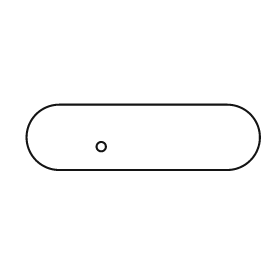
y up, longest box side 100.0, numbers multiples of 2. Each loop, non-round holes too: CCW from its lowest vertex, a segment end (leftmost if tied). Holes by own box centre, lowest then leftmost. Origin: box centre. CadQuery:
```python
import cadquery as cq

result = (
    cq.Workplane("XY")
    .moveTo(-36.0, -14.0)
    .lineTo(36.0, -14.0)
    .threePointArc((50.0, 0.0), (36.0, 14.0))
    .lineTo(-36.0, 14.0)
    .threePointArc((-50.0, 0.0), (-36.0, -14.0))
    .close()
    .moveTo(-18.0, -4.0)
    .circle(2.0)
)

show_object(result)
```